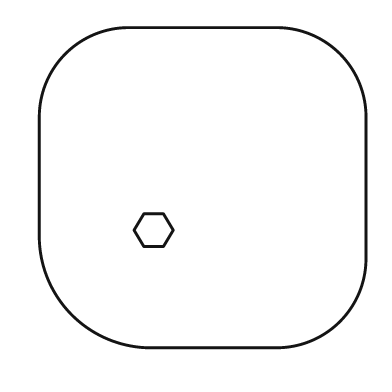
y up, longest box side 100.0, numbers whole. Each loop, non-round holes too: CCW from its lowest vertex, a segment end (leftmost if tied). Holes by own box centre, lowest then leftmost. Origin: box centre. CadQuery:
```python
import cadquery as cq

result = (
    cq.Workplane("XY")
    .moveTo(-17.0, -49.0)
    .lineTo(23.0, -49.0)
    .threePointArc((42.0, -41.0), (50.0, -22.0))
    .lineTo(50.0, 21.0)
    .threePointArc((42.0, 41.0), (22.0, 49.0))
    .lineTo(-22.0, 49.0)
    .threePointArc((-42.0, 41.0), (-50.0, 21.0))
    .lineTo(-50.0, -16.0)
    .threePointArc((-40.0, -39.0), (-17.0, -49.0))
    .close()
    .moveTo(-18.0, -18.0)
    .lineTo(-12.0, -18.0)
    .lineTo(-9.0, -13.0)
    .lineTo(-12.0, -8.0)
    .lineTo(-18.0, -8.0)
    .lineTo(-21.0, -13.0)
    .close()
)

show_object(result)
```